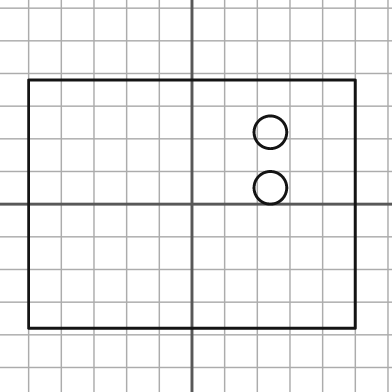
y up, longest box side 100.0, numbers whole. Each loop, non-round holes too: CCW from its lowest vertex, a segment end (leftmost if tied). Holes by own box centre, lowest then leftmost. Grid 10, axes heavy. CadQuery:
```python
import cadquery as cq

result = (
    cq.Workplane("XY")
    .moveTo(-50.0, -38.0)
    .lineTo(50.0, -38.0)
    .lineTo(50.0, 38.0)
    .lineTo(-50.0, 38.0)
    .close()
    .moveTo(24.0, 5.0)
    .circle(5.0)
    .moveTo(24.0, 22.0)
    .circle(5.0)
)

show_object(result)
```